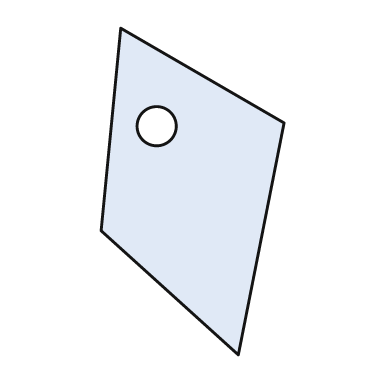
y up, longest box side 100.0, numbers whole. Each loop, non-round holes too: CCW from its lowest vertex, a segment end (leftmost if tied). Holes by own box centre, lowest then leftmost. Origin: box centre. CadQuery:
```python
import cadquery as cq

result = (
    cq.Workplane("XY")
    .moveTo(14.0, -50.0)
    .lineTo(28.0, 21.0)
    .lineTo(-22.0, 50.0)
    .lineTo(-28.0, -12.0)
    .close()
    .moveTo(-11.0, 20.0)
    .circle(6.0)
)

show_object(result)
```